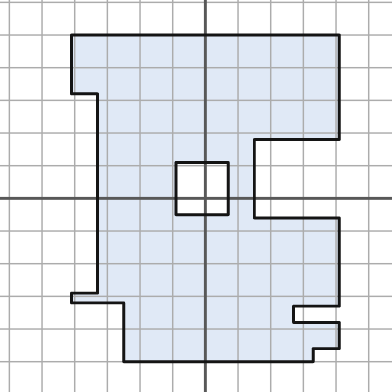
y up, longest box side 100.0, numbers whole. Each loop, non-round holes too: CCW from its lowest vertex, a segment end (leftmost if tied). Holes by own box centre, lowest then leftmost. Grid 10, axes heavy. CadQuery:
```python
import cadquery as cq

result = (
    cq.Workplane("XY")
    .moveTo(-25.0, -50.0)
    .lineTo(33.0, -50.0)
    .lineTo(33.0, -46.0)
    .lineTo(41.0, -46.0)
    .lineTo(41.0, -38.0)
    .lineTo(27.0, -38.0)
    .lineTo(27.0, -33.0)
    .lineTo(41.0, -33.0)
    .lineTo(41.0, -6.0)
    .lineTo(15.0, -6.0)
    .lineTo(15.0, 18.0)
    .lineTo(41.0, 18.0)
    .lineTo(41.0, 50.0)
    .lineTo(-41.0, 50.0)
    .lineTo(-41.0, 32.0)
    .lineTo(-33.0, 32.0)
    .lineTo(-33.0, -29.0)
    .lineTo(-41.0, -29.0)
    .lineTo(-41.0, -32.0)
    .lineTo(-25.0, -32.0)
    .close()
    .moveTo(-9.0, -5.0)
    .lineTo(7.0, -5.0)
    .lineTo(7.0, 11.0)
    .lineTo(-9.0, 11.0)
    .close()
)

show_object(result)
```